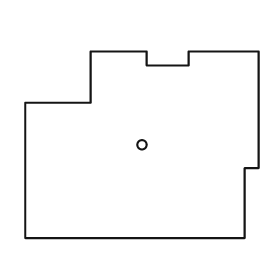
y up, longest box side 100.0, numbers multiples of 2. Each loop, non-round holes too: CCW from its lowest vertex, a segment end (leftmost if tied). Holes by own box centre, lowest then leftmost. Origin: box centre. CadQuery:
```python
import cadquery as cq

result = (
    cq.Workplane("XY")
    .moveTo(-50.0, -40.0)
    .lineTo(44.0, -40.0)
    .lineTo(44.0, -10.0)
    .lineTo(50.0, -10.0)
    .lineTo(50.0, 40.0)
    .lineTo(20.0, 40.0)
    .lineTo(20.0, 34.0)
    .lineTo(2.0, 34.0)
    .lineTo(2.0, 40.0)
    .lineTo(-22.0, 40.0)
    .lineTo(-22.0, 18.0)
    .lineTo(-50.0, 18.0)
    .close()
    .moveTo(0.0, 0.0)
    .circle(2.0)
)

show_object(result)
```